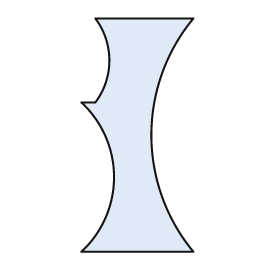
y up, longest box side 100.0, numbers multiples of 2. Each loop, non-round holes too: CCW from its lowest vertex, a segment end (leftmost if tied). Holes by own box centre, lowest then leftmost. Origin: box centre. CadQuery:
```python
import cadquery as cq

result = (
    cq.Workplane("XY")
    .moveTo(-24.0, -50.0)
    .lineTo(24.0, -50.0)
    .threePointArc((6.0, 0.0), (24.0, 50.0))
    .lineTo(-18.0, 50.0)
    .threePointArc((-12.0, 32.0), (-18.0, 14.0))
    .lineTo(-24.0, 14.0)
    .threePointArc((-10.0, -18.0), (-24.0, -50.0))
    .close()
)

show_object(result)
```